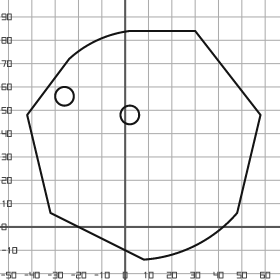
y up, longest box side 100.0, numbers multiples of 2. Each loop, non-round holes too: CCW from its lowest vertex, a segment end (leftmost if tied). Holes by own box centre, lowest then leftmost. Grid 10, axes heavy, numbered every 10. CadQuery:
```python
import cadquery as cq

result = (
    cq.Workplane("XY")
    .moveTo(8.0, -14.0)
    .threePointArc((30.0, -8.0), (48.0, 6.0))
    .lineTo(58.0, 48.0)
    .lineTo(30.0, 84.0)
    .lineTo(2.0, 84.0)
    .threePointArc((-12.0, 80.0), (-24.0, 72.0))
    .lineTo(-42.0, 48.0)
    .lineTo(-32.0, 6.0)
    .close()
    .moveTo(2.0, 48.0)
    .circle(4.0)
    .moveTo(-26.0, 56.0)
    .circle(4.0)
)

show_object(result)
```